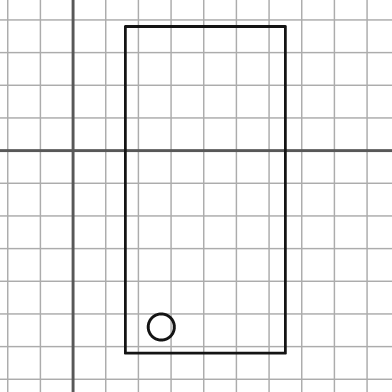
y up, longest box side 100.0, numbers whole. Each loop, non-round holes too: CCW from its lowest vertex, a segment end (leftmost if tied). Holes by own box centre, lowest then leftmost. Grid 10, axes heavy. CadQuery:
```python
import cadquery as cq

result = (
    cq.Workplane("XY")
    .moveTo(16.0, -62.0)
    .lineTo(65.0, -62.0)
    .lineTo(65.0, 38.0)
    .lineTo(16.0, 38.0)
    .close()
    .moveTo(27.0, -54.0)
    .circle(4.0)
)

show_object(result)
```